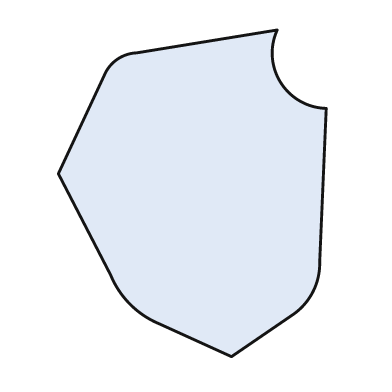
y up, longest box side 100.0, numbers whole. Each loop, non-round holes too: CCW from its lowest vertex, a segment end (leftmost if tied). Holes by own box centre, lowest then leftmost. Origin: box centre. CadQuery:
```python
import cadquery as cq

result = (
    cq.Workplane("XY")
    .moveTo(12.0, -50.0)
    .lineTo(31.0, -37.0)
    .threePointArc((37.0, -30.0), (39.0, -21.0))
    .lineTo(41.0, 26.0)
    .threePointArc((27.0, 34.0), (26.0, 50.0))
    .lineTo(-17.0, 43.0)
    .threePointArc((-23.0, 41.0), (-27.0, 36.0))
    .lineTo(-41.0, 6.0)
    .lineTo(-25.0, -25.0)
    .threePointArc((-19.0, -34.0), (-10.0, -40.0))
    .close()
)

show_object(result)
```